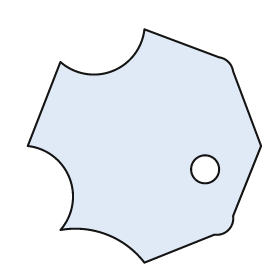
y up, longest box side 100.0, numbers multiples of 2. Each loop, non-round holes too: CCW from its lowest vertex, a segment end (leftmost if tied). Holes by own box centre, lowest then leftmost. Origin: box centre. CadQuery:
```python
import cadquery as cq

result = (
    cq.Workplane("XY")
    .moveTo(0.0, -50.0)
    .lineTo(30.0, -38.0)
    .threePointArc((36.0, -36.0), (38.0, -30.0))
    .lineTo(50.0, 0.0)
    .lineTo(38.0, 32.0)
    .threePointArc((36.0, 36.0), (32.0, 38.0))
    .lineTo(0.0, 50.0)
    .threePointArc((-14.0, 32.0), (-36.0, 36.0))
    .lineTo(-50.0, 0.0)
    .threePointArc((-32.0, -14.0), (-36.0, -36.0))
    .threePointArc((-16.0, -38.0), (0.0, -50.0))
    .close()
    .moveTo(26.0, -10.0)
    .circle(6.0)
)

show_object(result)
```